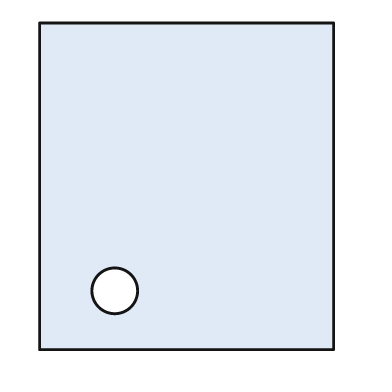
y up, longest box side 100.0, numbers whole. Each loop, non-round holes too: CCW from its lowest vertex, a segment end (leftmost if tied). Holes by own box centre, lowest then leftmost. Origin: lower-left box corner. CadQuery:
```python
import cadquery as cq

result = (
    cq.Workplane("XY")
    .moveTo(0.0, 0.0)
    .lineTo(90.0, 0.0)
    .lineTo(90.0, 100.0)
    .lineTo(0.0, 100.0)
    .close()
    .moveTo(23.0, 18.0)
    .circle(7.0)
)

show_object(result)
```